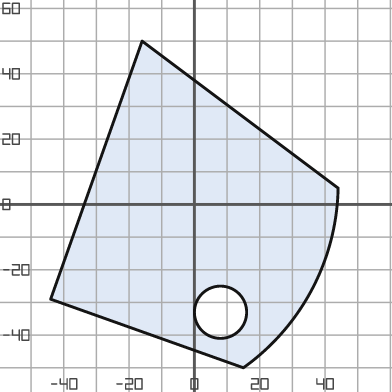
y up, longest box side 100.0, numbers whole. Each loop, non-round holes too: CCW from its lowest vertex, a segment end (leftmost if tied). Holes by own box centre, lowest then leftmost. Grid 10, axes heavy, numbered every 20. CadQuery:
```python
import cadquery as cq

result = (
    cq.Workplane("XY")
    .moveTo(15.0, -50.0)
    .threePointArc((36.0, -26.0), (44.0, 5.0))
    .lineTo(-16.0, 50.0)
    .lineTo(-44.0, -29.0)
    .close()
    .moveTo(8.0, -33.0)
    .circle(8.0)
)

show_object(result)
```